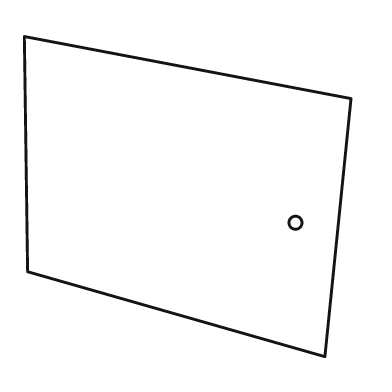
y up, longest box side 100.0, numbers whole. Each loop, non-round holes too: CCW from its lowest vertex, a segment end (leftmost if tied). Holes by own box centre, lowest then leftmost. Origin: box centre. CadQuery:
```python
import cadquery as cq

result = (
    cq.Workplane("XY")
    .moveTo(42.0, -49.0)
    .lineTo(50.0, 30.0)
    .lineTo(-50.0, 49.0)
    .lineTo(-49.0, -23.0)
    .close()
    .moveTo(33.0, -8.0)
    .circle(2.0)
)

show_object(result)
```